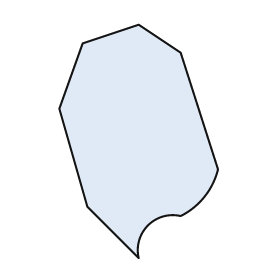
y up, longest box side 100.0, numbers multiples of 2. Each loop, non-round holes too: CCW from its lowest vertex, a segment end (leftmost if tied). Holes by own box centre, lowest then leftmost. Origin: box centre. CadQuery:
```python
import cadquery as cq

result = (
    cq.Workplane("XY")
    .moveTo(0.0, -50.0)
    .threePointArc((4.0, -36.0), (18.0, -32.0))
    .threePointArc((28.0, -24.0), (34.0, -12.0))
    .lineTo(18.0, 38.0)
    .lineTo(0.0, 50.0)
    .lineTo(-24.0, 42.0)
    .lineTo(-34.0, 14.0)
    .lineTo(-22.0, -28.0)
    .close()
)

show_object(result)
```